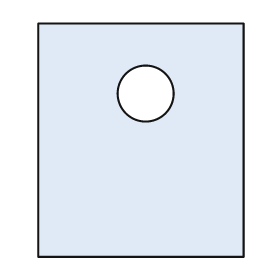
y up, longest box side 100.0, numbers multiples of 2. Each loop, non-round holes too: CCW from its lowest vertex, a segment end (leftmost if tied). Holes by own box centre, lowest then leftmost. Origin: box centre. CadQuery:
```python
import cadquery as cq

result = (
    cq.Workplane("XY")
    .moveTo(-44.0, -50.0)
    .lineTo(44.0, -50.0)
    .lineTo(44.0, 50.0)
    .lineTo(-44.0, 50.0)
    .close()
    .moveTo(2.0, 20.0)
    .circle(12.0)
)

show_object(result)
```